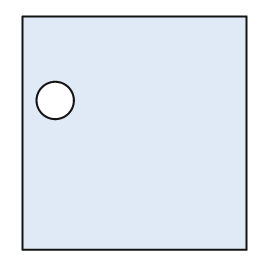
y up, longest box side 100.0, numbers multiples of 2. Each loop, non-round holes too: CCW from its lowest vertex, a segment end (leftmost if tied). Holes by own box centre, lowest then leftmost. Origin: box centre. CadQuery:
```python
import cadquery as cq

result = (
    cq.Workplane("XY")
    .moveTo(-48.0, -50.0)
    .lineTo(48.0, -50.0)
    .lineTo(48.0, 50.0)
    .lineTo(-48.0, 50.0)
    .close()
    .moveTo(-34.0, 14.0)
    .circle(8.0)
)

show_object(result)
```